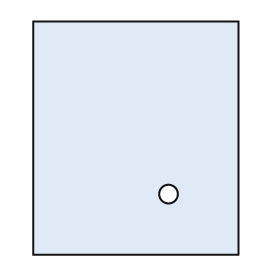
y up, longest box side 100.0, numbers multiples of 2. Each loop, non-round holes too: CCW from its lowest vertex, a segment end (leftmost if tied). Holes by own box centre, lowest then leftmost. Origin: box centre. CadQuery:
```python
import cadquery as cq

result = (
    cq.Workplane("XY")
    .moveTo(-44.0, -50.0)
    .lineTo(44.0, -50.0)
    .lineTo(44.0, 50.0)
    .lineTo(-44.0, 50.0)
    .close()
    .moveTo(14.0, -24.0)
    .circle(4.0)
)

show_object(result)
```